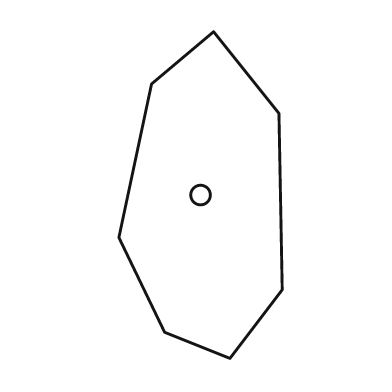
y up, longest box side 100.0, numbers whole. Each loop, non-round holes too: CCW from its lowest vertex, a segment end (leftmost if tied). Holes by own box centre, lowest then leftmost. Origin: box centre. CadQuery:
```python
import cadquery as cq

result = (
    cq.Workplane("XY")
    .moveTo(9.0, -50.0)
    .lineTo(25.0, -29.0)
    .lineTo(24.0, 25.0)
    .lineTo(4.0, 50.0)
    .lineTo(-15.0, 34.0)
    .lineTo(-25.0, -13.0)
    .lineTo(-11.0, -42.0)
    .close()
    .moveTo(0.0, 0.0)
    .circle(3.0)
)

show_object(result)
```